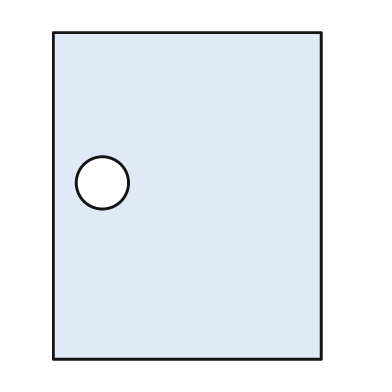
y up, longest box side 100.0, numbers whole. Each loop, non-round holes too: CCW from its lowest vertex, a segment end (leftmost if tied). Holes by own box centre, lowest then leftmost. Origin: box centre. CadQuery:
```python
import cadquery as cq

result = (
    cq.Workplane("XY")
    .moveTo(-41.0, -50.0)
    .lineTo(41.0, -50.0)
    .lineTo(41.0, 50.0)
    .lineTo(-41.0, 50.0)
    .close()
    .moveTo(-26.0, 4.0)
    .circle(8.0)
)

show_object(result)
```